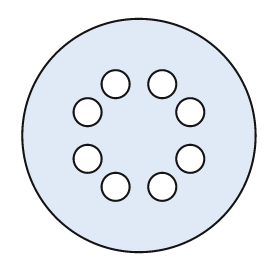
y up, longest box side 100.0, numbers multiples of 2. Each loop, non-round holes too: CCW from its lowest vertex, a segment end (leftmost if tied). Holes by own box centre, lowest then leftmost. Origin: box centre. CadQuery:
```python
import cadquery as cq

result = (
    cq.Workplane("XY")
    .moveTo(0.0, 0.0)
    .circle(50.0)
    .moveTo(-10.0, -22.0)
    .circle(6.0)
    .moveTo(10.0, -22.0)
    .circle(6.0)
    .moveTo(-22.0, -10.0)
    .circle(6.0)
    .moveTo(22.0, -10.0)
    .circle(6.0)
    .moveTo(-22.0, 10.0)
    .circle(6.0)
    .moveTo(22.0, 10.0)
    .circle(6.0)
    .moveTo(-10.0, 22.0)
    .circle(6.0)
    .moveTo(10.0, 22.0)
    .circle(6.0)
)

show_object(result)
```